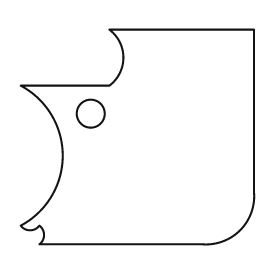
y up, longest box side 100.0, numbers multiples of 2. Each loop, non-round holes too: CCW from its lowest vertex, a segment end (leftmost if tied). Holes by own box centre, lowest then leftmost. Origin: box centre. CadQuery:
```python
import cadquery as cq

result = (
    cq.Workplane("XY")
    .moveTo(-42.0, -46.0)
    .lineTo(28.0, -46.0)
    .threePointArc((44.0, -40.0), (50.0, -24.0))
    .lineTo(50.0, 46.0)
    .lineTo(-12.0, 46.0)
    .threePointArc((-6.0, 34.0), (-12.0, 22.0))
    .lineTo(-50.0, 22.0)
    .threePointArc((-32.0, -8.0), (-50.0, -38.0))
    .threePointArc((-46.0, -40.0), (-42.0, -38.0))
    .threePointArc((-40.0, -42.0), (-42.0, -46.0))
    .close()
    .moveTo(-20.0, 10.0)
    .circle(6.0)
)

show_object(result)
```